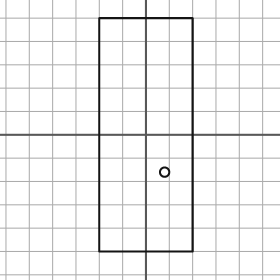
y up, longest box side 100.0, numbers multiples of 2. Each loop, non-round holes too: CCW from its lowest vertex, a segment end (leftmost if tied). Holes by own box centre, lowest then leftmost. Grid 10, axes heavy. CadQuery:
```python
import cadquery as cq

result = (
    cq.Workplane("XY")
    .moveTo(-20.0, -50.0)
    .lineTo(20.0, -50.0)
    .lineTo(20.0, 50.0)
    .lineTo(-20.0, 50.0)
    .close()
    .moveTo(8.0, -16.0)
    .circle(2.0)
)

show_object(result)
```